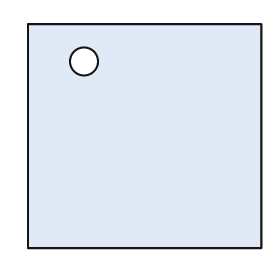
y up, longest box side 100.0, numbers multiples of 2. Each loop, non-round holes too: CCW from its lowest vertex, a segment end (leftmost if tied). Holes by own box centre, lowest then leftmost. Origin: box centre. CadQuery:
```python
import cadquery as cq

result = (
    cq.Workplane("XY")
    .moveTo(-50.0, -48.0)
    .lineTo(50.0, -48.0)
    .lineTo(50.0, 48.0)
    .lineTo(-50.0, 48.0)
    .close()
    .moveTo(-26.0, 32.0)
    .circle(6.0)
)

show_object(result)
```